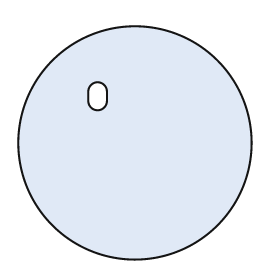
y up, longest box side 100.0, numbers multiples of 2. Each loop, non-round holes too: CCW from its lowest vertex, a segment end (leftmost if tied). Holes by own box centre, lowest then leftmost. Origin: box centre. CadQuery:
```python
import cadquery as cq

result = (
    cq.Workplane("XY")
    .moveTo(0.0, 0.0)
    .circle(50.0)
    .moveTo(-20.0, 18.0)
    .threePointArc((-16.0, 14.0), (-12.0, 18.0))
    .lineTo(-12.0, 22.0)
    .threePointArc((-16.0, 26.0), (-20.0, 22.0))
    .close()
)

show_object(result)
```